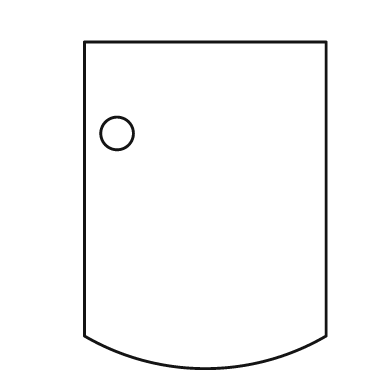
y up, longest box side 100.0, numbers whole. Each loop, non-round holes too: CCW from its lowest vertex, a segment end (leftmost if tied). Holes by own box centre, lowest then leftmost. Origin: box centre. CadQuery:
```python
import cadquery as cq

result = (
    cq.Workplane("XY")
    .moveTo(-37.0, -40.0)
    .threePointArc((0.0, -50.0), (37.0, -40.0))
    .lineTo(37.0, 50.0)
    .lineTo(-37.0, 50.0)
    .close()
    .moveTo(-27.0, 22.0)
    .circle(5.0)
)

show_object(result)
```